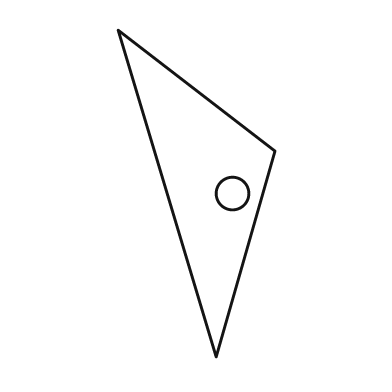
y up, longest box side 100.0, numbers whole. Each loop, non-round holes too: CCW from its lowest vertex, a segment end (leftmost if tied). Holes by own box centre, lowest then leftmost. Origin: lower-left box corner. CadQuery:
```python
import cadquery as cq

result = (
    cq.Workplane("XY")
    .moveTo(30.0, 0.0)
    .lineTo(48.0, 63.0)
    .lineTo(0.0, 100.0)
    .close()
    .moveTo(35.0, 50.0)
    .circle(5.0)
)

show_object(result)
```